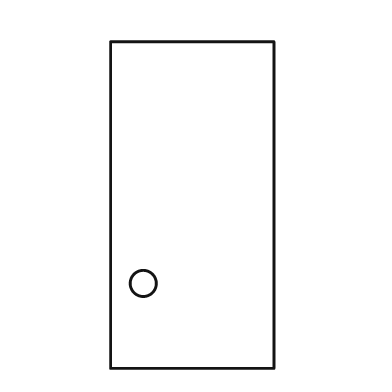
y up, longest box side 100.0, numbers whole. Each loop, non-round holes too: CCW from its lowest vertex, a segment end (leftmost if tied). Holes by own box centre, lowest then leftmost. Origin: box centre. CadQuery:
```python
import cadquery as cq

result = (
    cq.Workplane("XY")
    .moveTo(-25.0, -50.0)
    .lineTo(25.0, -50.0)
    .lineTo(25.0, 50.0)
    .lineTo(-25.0, 50.0)
    .close()
    .moveTo(-15.0, -24.0)
    .circle(4.0)
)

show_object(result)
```